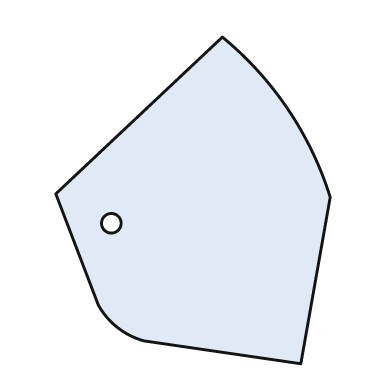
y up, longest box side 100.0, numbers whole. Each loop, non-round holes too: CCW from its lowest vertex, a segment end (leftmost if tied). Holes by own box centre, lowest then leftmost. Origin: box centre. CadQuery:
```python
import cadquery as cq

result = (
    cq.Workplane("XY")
    .moveTo(33.0, -50.0)
    .lineTo(42.0, 1.0)
    .threePointArc((29.0, 28.0), (9.0, 50.0))
    .lineTo(-42.0, 2.0)
    .lineTo(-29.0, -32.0)
    .threePointArc((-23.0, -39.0), (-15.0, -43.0))
    .close()
    .moveTo(-25.0, -7.0)
    .circle(3.0)
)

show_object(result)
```